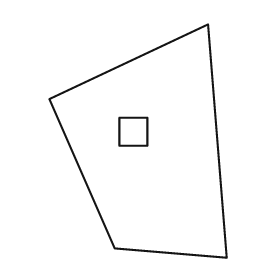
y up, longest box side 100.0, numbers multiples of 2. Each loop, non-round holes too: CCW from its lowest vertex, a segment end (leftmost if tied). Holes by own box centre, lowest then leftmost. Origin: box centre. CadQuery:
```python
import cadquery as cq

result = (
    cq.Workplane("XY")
    .moveTo(38.0, -50.0)
    .lineTo(30.0, 50.0)
    .lineTo(-38.0, 18.0)
    .lineTo(-10.0, -46.0)
    .close()
    .moveTo(-8.0, -2.0)
    .lineTo(4.0, -2.0)
    .lineTo(4.0, 10.0)
    .lineTo(-8.0, 10.0)
    .close()
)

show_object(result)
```